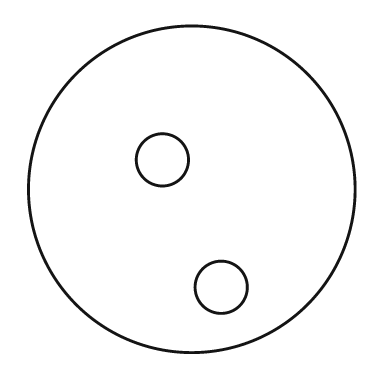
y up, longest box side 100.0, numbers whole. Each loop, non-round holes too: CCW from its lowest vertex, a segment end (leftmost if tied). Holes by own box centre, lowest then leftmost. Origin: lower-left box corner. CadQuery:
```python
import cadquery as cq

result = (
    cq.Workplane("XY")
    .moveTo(50.0, 50.0)
    .circle(50.0)
    .moveTo(59.0, 20.0)
    .circle(8.0)
    .moveTo(41.0, 59.0)
    .circle(8.0)
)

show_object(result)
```